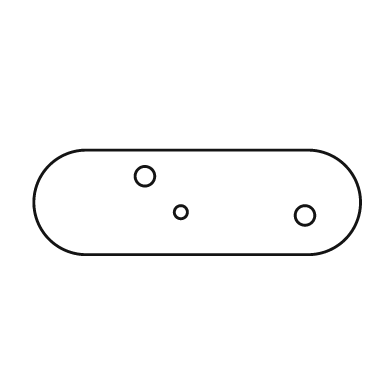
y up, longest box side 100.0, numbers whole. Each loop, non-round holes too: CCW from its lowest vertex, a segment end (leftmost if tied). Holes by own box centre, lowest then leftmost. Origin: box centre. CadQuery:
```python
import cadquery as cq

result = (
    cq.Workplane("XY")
    .moveTo(-34.0, -16.0)
    .lineTo(34.0, -16.0)
    .threePointArc((50.0, 0.0), (34.0, 16.0))
    .lineTo(-34.0, 16.0)
    .threePointArc((-50.0, 0.0), (-34.0, -16.0))
    .close()
    .moveTo(33.0, -4.0)
    .circle(3.0)
    .moveTo(-5.0, -3.0)
    .circle(2.0)
    .moveTo(-16.0, 8.0)
    .circle(3.0)
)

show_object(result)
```